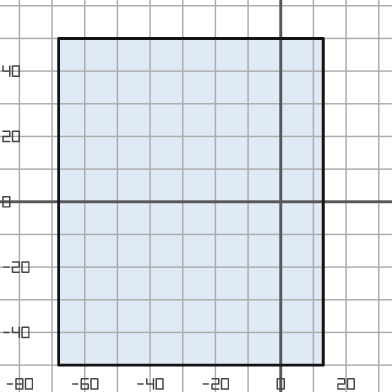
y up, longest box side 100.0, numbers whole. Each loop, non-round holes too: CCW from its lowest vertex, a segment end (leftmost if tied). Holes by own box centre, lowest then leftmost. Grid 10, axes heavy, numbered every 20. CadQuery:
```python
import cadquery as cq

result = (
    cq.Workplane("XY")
    .moveTo(-68.0, -50.0)
    .lineTo(13.0, -50.0)
    .lineTo(13.0, 50.0)
    .lineTo(-68.0, 50.0)
    .close()
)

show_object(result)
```